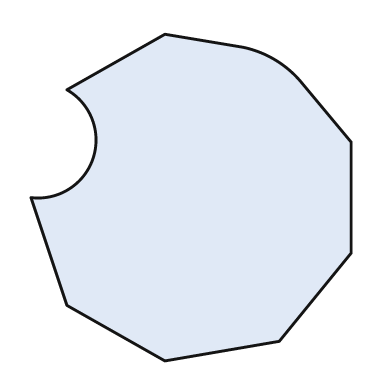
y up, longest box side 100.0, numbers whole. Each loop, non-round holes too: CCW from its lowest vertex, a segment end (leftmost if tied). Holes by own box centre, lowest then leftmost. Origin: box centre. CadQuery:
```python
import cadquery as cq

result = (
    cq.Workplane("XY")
    .moveTo(-8.0, -50.0)
    .lineTo(27.0, -44.0)
    .lineTo(49.0, -17.0)
    .lineTo(49.0, 17.0)
    .lineTo(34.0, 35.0)
    .threePointArc((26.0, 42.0), (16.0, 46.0))
    .lineTo(-8.0, 50.0)
    .lineTo(-38.0, 33.0)
    .threePointArc((-30.0, 12.0), (-49.0, 0.0))
    .lineTo(-38.0, -33.0)
    .close()
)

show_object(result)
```